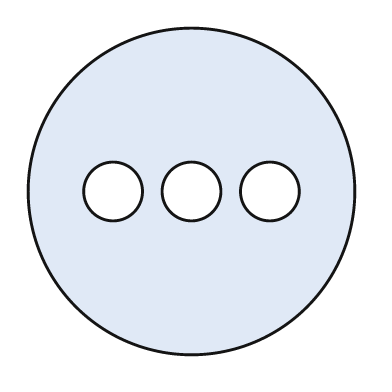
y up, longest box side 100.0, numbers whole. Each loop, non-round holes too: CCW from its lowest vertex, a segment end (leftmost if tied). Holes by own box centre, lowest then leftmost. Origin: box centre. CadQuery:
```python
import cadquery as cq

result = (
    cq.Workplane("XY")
    .moveTo(0.0, 0.0)
    .circle(50.0)
    .moveTo(-24.0, 0.0)
    .circle(9.0)
    .moveTo(0.0, 0.0)
    .circle(9.0)
    .moveTo(24.0, 0.0)
    .circle(9.0)
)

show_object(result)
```